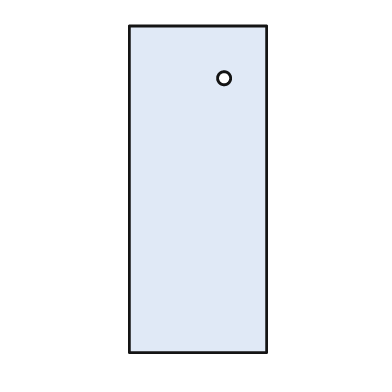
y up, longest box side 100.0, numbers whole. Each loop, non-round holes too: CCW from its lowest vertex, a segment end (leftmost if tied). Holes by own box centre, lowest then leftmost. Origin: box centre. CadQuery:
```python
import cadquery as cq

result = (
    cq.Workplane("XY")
    .moveTo(-21.0, -50.0)
    .lineTo(21.0, -50.0)
    .lineTo(21.0, 50.0)
    .lineTo(-21.0, 50.0)
    .close()
    .moveTo(8.0, 34.0)
    .circle(2.0)
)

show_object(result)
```